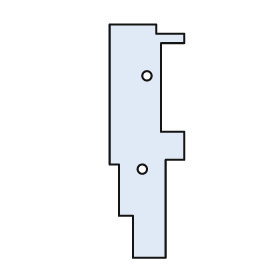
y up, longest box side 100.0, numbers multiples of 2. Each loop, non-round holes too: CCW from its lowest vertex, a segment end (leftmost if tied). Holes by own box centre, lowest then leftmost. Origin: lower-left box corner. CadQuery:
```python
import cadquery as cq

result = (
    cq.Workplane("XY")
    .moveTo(10.0, 0.0)
    .lineTo(24.0, 0.0)
    .lineTo(24.0, 42.0)
    .lineTo(32.0, 42.0)
    .lineTo(32.0, 54.0)
    .lineTo(22.0, 54.0)
    .lineTo(22.0, 92.0)
    .lineTo(32.0, 92.0)
    .lineTo(32.0, 96.0)
    .lineTo(20.0, 96.0)
    .lineTo(20.0, 100.0)
    .lineTo(0.0, 100.0)
    .lineTo(0.0, 40.0)
    .lineTo(4.0, 40.0)
    .lineTo(4.0, 18.0)
    .lineTo(10.0, 18.0)
    .close()
    .moveTo(14.0, 38.0)
    .circle(2.0)
    .moveTo(16.0, 78.0)
    .circle(2.0)
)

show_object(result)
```